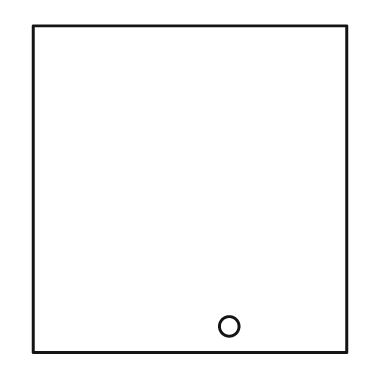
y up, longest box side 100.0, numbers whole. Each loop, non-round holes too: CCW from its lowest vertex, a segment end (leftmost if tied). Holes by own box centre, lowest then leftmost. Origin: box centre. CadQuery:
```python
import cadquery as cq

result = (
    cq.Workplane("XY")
    .moveTo(-48.0, -50.0)
    .lineTo(48.0, -50.0)
    .lineTo(48.0, 50.0)
    .lineTo(-48.0, 50.0)
    .close()
    .moveTo(12.0, -42.0)
    .circle(3.0)
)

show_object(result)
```